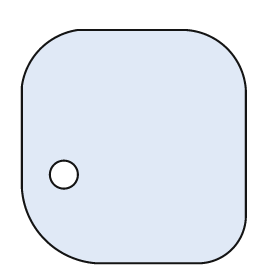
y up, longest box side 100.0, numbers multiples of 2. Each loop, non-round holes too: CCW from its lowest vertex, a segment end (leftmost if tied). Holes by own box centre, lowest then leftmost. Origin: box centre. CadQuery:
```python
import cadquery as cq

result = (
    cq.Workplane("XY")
    .moveTo(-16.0, -50.0)
    .lineTo(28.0, -50.0)
    .threePointArc((42.0, -44.0), (48.0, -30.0))
    .lineTo(48.0, 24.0)
    .threePointArc((40.0, 42.0), (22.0, 50.0))
    .lineTo(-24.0, 50.0)
    .threePointArc((-40.0, 42.0), (-48.0, 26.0))
    .lineTo(-48.0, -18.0)
    .threePointArc((-38.0, -40.0), (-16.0, -50.0))
    .close()
    .moveTo(-30.0, -12.0)
    .circle(6.0)
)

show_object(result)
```